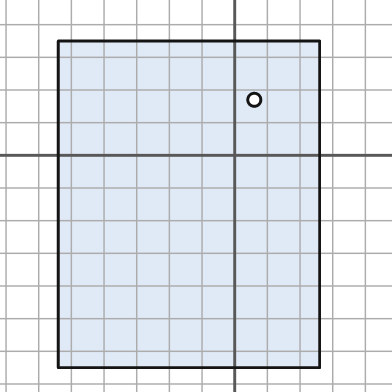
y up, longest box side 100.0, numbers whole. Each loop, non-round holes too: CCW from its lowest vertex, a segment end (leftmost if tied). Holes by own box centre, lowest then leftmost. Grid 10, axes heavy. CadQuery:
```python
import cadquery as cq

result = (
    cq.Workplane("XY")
    .moveTo(-54.0, -65.0)
    .lineTo(26.0, -65.0)
    .lineTo(26.0, 35.0)
    .lineTo(-54.0, 35.0)
    .close()
    .moveTo(6.0, 17.0)
    .circle(2.0)
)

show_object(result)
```